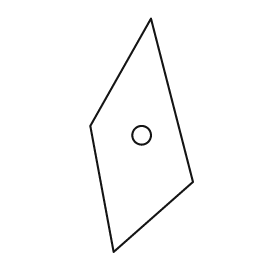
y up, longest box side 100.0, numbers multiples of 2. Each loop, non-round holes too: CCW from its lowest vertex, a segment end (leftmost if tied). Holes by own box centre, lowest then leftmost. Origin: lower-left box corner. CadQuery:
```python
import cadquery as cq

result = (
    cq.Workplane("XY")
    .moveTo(10.0, 0.0)
    .lineTo(44.0, 30.0)
    .lineTo(26.0, 100.0)
    .lineTo(0.0, 54.0)
    .close()
    .moveTo(22.0, 50.0)
    .circle(4.0)
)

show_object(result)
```